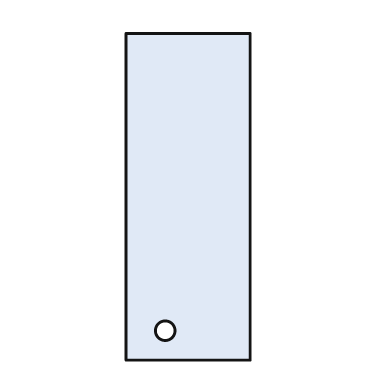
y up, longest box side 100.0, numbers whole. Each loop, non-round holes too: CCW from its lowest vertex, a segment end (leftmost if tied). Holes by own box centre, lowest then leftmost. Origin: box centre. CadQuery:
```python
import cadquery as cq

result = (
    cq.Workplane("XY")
    .moveTo(-19.0, -50.0)
    .lineTo(19.0, -50.0)
    .lineTo(19.0, 50.0)
    .lineTo(-19.0, 50.0)
    .close()
    .moveTo(-7.0, -41.0)
    .circle(3.0)
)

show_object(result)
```